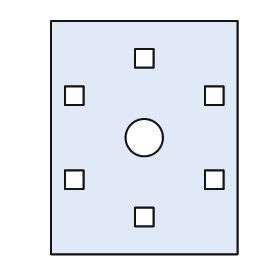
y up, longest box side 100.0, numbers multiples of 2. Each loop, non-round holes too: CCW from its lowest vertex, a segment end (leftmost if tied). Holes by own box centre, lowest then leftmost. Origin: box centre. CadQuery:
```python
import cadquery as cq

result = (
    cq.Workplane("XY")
    .moveTo(-40.0, -50.0)
    .lineTo(40.0, -50.0)
    .lineTo(40.0, 50.0)
    .lineTo(-40.0, 50.0)
    .close()
    .moveTo(-4.0, -38.0)
    .lineTo(4.0, -38.0)
    .lineTo(4.0, -30.0)
    .lineTo(-4.0, -30.0)
    .close()
    .moveTo(-34.0, -22.0)
    .lineTo(-26.0, -22.0)
    .lineTo(-26.0, -14.0)
    .lineTo(-34.0, -14.0)
    .close()
    .moveTo(26.0, -22.0)
    .lineTo(34.0, -22.0)
    .lineTo(34.0, -14.0)
    .lineTo(26.0, -14.0)
    .close()
    .moveTo(0.0, 0.0)
    .circle(8.0)
    .moveTo(-34.0, 14.0)
    .lineTo(-26.0, 14.0)
    .lineTo(-26.0, 22.0)
    .lineTo(-34.0, 22.0)
    .close()
    .moveTo(26.0, 14.0)
    .lineTo(34.0, 14.0)
    .lineTo(34.0, 22.0)
    .lineTo(26.0, 22.0)
    .close()
    .moveTo(-4.0, 30.0)
    .lineTo(4.0, 30.0)
    .lineTo(4.0, 38.0)
    .lineTo(-4.0, 38.0)
    .close()
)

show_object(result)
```